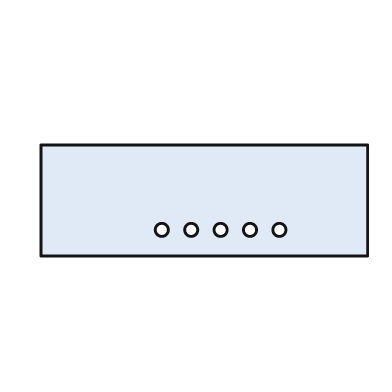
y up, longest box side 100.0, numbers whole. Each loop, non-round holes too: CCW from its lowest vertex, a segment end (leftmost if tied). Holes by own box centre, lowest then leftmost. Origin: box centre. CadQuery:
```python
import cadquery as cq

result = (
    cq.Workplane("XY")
    .moveTo(-50.0, -17.0)
    .lineTo(50.0, -17.0)
    .lineTo(50.0, 17.0)
    .lineTo(-50.0, 17.0)
    .close()
    .moveTo(-13.0, -9.0)
    .circle(2.0)
    .moveTo(-4.0, -9.0)
    .circle(2.0)
    .moveTo(5.0, -9.0)
    .circle(2.0)
    .moveTo(14.0, -9.0)
    .circle(2.0)
    .moveTo(23.0, -9.0)
    .circle(2.0)
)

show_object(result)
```